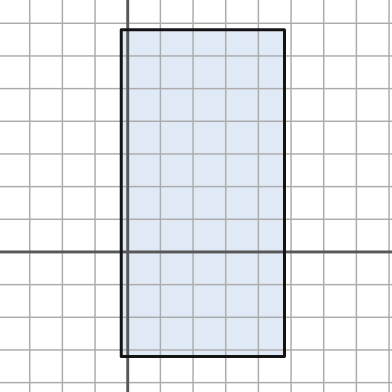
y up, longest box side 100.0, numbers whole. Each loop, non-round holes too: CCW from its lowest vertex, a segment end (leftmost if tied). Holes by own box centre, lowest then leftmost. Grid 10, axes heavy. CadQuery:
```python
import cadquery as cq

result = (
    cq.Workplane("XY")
    .moveTo(-2.0, -32.0)
    .lineTo(48.0, -32.0)
    .lineTo(48.0, 68.0)
    .lineTo(-2.0, 68.0)
    .close()
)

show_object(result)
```